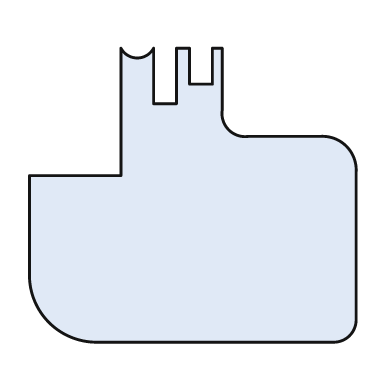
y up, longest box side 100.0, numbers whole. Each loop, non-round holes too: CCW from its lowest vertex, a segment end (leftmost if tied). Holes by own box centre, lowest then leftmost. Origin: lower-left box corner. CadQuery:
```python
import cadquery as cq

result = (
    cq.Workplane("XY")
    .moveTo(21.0, 0.0)
    .lineTo(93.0, 0.0)
    .threePointArc((98.0, 2.0), (100.0, 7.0))
    .lineTo(100.0, 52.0)
    .threePointArc((97.0, 60.0), (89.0, 63.0))
    .lineTo(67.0, 63.0)
    .threePointArc((61.0, 65.0), (59.0, 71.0))
    .lineTo(59.0, 90.0)
    .lineTo(56.0, 90.0)
    .lineTo(56.0, 79.0)
    .lineTo(49.0, 79.0)
    .lineTo(49.0, 90.0)
    .lineTo(45.0, 90.0)
    .lineTo(45.0, 73.0)
    .lineTo(38.0, 73.0)
    .lineTo(38.0, 90.0)
    .threePointArc((33.0, 87.0), (28.0, 90.0))
    .lineTo(28.0, 51.0)
    .lineTo(0.0, 51.0)
    .lineTo(0.0, 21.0)
    .threePointArc((6.0, 6.0), (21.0, 0.0))
    .close()
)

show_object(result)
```